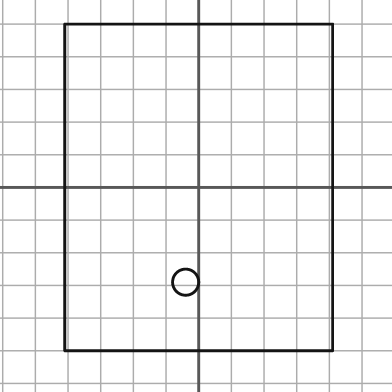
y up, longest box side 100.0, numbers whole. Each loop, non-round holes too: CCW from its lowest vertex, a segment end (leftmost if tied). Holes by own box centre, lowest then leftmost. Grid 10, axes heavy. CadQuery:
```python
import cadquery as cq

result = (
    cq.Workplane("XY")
    .moveTo(-41.0, -50.0)
    .lineTo(41.0, -50.0)
    .lineTo(41.0, 50.0)
    .lineTo(-41.0, 50.0)
    .close()
    .moveTo(-4.0, -29.0)
    .circle(4.0)
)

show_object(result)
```